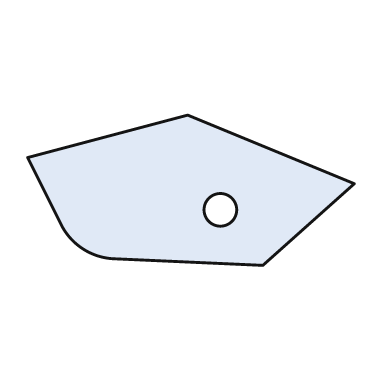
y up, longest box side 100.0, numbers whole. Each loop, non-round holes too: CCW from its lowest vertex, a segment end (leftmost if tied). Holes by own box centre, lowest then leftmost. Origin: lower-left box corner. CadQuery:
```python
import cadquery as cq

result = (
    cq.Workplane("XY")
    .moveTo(72.0, 0.0)
    .lineTo(100.0, 25.0)
    .lineTo(49.0, 46.0)
    .lineTo(0.0, 33.0)
    .lineTo(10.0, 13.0)
    .threePointArc((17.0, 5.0), (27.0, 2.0))
    .close()
    .moveTo(59.0, 17.0)
    .circle(5.0)
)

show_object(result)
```